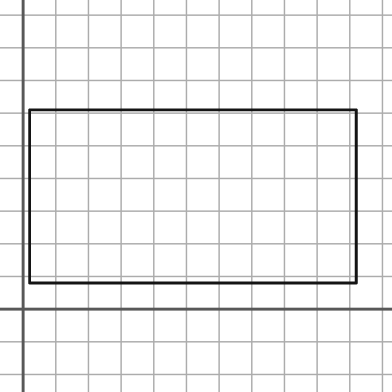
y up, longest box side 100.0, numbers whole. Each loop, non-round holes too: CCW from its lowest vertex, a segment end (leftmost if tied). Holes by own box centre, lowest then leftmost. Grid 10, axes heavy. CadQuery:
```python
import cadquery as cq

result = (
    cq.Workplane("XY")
    .moveTo(2.0, 8.0)
    .lineTo(102.0, 8.0)
    .lineTo(102.0, 61.0)
    .lineTo(2.0, 61.0)
    .close()
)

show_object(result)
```